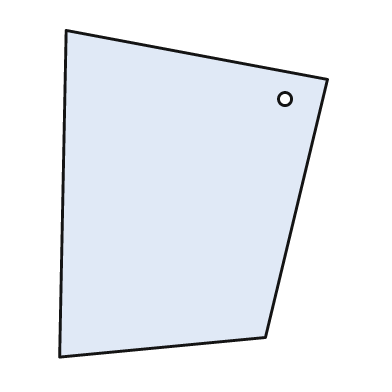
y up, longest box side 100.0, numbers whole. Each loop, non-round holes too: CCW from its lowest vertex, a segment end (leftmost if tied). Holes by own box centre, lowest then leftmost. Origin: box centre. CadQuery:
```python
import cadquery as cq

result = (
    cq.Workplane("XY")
    .moveTo(-41.0, -50.0)
    .lineTo(22.0, -44.0)
    .lineTo(41.0, 35.0)
    .lineTo(-39.0, 50.0)
    .close()
    .moveTo(28.0, 29.0)
    .circle(2.0)
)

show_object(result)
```